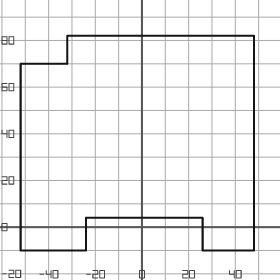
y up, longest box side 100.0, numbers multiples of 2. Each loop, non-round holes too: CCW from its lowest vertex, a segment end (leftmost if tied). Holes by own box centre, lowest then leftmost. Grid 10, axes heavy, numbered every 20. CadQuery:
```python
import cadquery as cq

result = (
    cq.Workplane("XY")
    .moveTo(-52.0, -10.0)
    .lineTo(-24.0, -10.0)
    .lineTo(-24.0, 4.0)
    .lineTo(26.0, 4.0)
    .lineTo(26.0, -10.0)
    .lineTo(48.0, -10.0)
    .lineTo(48.0, 82.0)
    .lineTo(-32.0, 82.0)
    .lineTo(-32.0, 70.0)
    .lineTo(-52.0, 70.0)
    .close()
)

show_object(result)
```